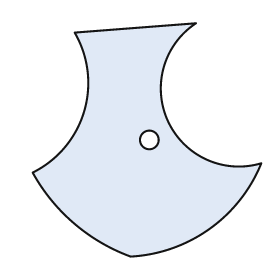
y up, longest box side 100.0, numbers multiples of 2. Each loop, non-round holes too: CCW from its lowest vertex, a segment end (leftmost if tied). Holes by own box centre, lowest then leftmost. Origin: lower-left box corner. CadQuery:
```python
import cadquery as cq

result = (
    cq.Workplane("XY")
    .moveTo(42.0, 0.0)
    .threePointArc((76.0, 12.0), (98.0, 40.0))
    .threePointArc((58.0, 58.0), (70.0, 100.0))
    .lineTo(18.0, 96.0)
    .threePointArc((22.0, 62.0), (0.0, 36.0))
    .threePointArc((18.0, 14.0), (42.0, 0.0))
    .close()
    .moveTo(50.0, 50.0)
    .circle(4.0)
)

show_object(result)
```